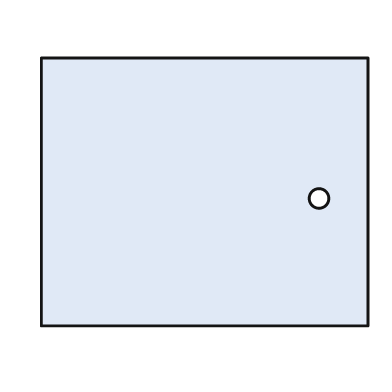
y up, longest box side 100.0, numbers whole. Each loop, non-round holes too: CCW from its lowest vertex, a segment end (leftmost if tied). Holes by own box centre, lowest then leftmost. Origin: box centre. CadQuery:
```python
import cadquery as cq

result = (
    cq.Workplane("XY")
    .moveTo(-50.0, -41.0)
    .lineTo(50.0, -41.0)
    .lineTo(50.0, 41.0)
    .lineTo(-50.0, 41.0)
    .close()
    .moveTo(35.0, -2.0)
    .circle(3.0)
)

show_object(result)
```